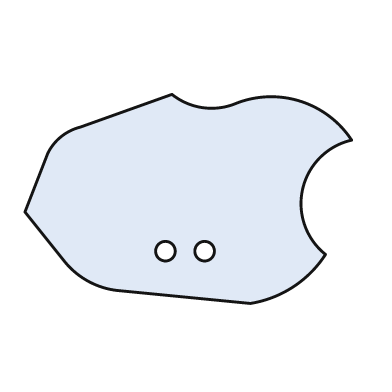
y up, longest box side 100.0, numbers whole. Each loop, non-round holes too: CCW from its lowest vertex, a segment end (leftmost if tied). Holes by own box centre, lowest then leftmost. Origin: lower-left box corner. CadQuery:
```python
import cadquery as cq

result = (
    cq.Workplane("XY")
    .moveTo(69.0, 0.0)
    .threePointArc((82.0, 5.0), (92.0, 15.0))
    .threePointArc((85.0, 35.0), (100.0, 50.0))
    .threePointArc((84.0, 62.0), (64.0, 61.0))
    .threePointArc((54.0, 60.0), (45.0, 64.0))
    .lineTo(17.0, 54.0)
    .threePointArc((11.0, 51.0), (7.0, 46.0))
    .lineTo(0.0, 28.0)
    .lineTo(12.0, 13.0)
    .threePointArc((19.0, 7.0), (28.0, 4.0))
    .close()
    .moveTo(43.0, 16.0)
    .circle(3.0)
    .moveTo(55.0, 16.0)
    .circle(3.0)
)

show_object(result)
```